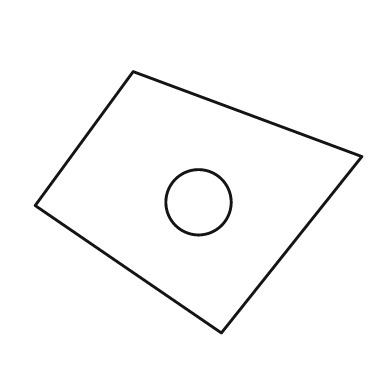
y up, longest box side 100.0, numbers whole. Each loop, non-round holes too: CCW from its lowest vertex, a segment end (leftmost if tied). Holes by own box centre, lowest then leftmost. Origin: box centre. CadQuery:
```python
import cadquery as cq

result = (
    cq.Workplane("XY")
    .moveTo(7.0, -40.0)
    .lineTo(50.0, 14.0)
    .lineTo(-20.0, 40.0)
    .lineTo(-50.0, -1.0)
    .close()
    .moveTo(0.0, 0.0)
    .circle(10.0)
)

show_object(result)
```